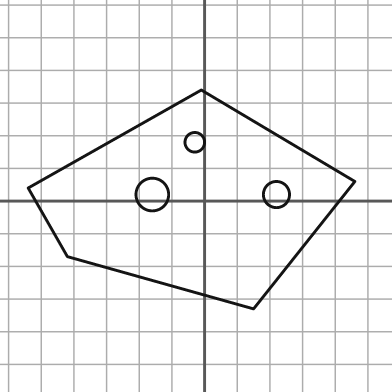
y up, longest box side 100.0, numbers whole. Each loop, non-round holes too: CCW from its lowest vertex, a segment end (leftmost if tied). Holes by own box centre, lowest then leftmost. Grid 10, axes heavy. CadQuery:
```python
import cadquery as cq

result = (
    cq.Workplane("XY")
    .moveTo(15.0, -33.0)
    .lineTo(46.0, 6.0)
    .lineTo(-1.0, 34.0)
    .lineTo(-54.0, 4.0)
    .lineTo(-42.0, -17.0)
    .close()
    .moveTo(-16.0, 2.0)
    .circle(5.0)
    .moveTo(22.0, 2.0)
    .circle(4.0)
    .moveTo(-3.0, 18.0)
    .circle(3.0)
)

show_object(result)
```